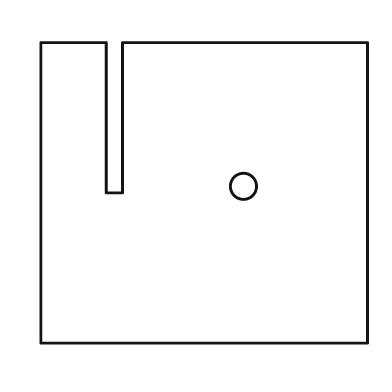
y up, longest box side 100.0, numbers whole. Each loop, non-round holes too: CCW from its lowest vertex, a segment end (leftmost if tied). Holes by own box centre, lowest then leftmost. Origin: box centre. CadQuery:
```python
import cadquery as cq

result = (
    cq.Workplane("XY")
    .moveTo(-50.0, -46.0)
    .lineTo(50.0, -46.0)
    .lineTo(50.0, 46.0)
    .lineTo(-25.0, 46.0)
    .lineTo(-25.0, 0.0)
    .lineTo(-30.0, 0.0)
    .lineTo(-30.0, 46.0)
    .lineTo(-50.0, 46.0)
    .close()
    .moveTo(12.0, 2.0)
    .circle(4.0)
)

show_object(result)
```